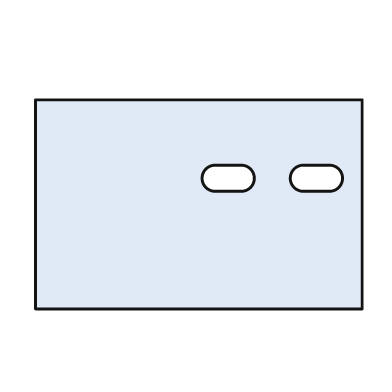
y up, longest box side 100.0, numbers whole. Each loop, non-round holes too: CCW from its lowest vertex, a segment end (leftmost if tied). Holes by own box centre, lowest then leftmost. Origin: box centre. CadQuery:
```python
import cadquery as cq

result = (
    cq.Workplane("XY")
    .moveTo(-50.0, -32.0)
    .lineTo(50.0, -32.0)
    .lineTo(50.0, 32.0)
    .lineTo(-50.0, 32.0)
    .close()
    .moveTo(5.0, 4.0)
    .lineTo(13.0, 4.0)
    .threePointArc((17.0, 8.0), (13.0, 12.0))
    .lineTo(5.0, 12.0)
    .threePointArc((1.0, 8.0), (5.0, 4.0))
    .close()
    .moveTo(32.0, 4.0)
    .lineTo(40.0, 4.0)
    .threePointArc((44.0, 8.0), (40.0, 12.0))
    .lineTo(32.0, 12.0)
    .threePointArc((28.0, 8.0), (32.0, 4.0))
    .close()
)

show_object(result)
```